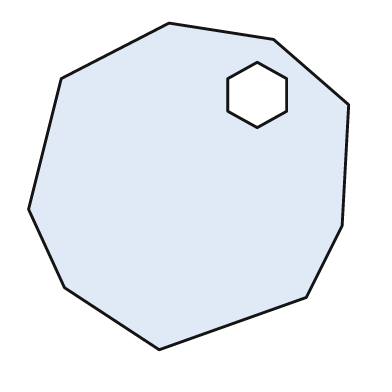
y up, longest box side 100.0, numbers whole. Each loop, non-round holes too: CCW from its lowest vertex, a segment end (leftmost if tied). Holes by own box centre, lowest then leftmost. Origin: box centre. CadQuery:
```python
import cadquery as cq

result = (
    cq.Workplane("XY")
    .moveTo(-9.0, -50.0)
    .lineTo(36.0, -34.0)
    .lineTo(47.0, -12.0)
    .lineTo(49.0, 25.0)
    .lineTo(26.0, 45.0)
    .lineTo(-6.0, 50.0)
    .lineTo(-39.0, 33.0)
    .lineTo(-49.0, -7.0)
    .lineTo(-38.0, -31.0)
    .close()
    .moveTo(21.0, 18.0)
    .lineTo(30.0, 23.0)
    .lineTo(30.0, 33.0)
    .lineTo(21.0, 38.0)
    .lineTo(12.0, 33.0)
    .lineTo(12.0, 23.0)
    .close()
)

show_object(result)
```